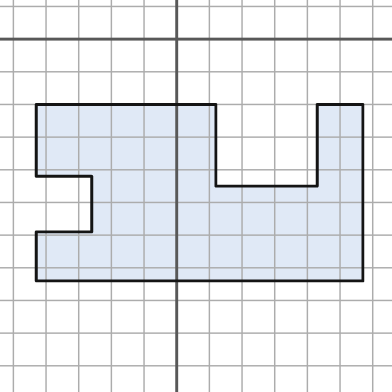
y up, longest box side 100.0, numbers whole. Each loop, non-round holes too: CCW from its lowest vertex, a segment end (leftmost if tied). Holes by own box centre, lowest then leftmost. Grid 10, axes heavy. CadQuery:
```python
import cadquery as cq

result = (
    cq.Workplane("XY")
    .moveTo(-43.0, -74.0)
    .lineTo(57.0, -74.0)
    .lineTo(57.0, -20.0)
    .lineTo(43.0, -20.0)
    .lineTo(43.0, -45.0)
    .lineTo(12.0, -45.0)
    .lineTo(12.0, -20.0)
    .lineTo(-43.0, -20.0)
    .lineTo(-43.0, -42.0)
    .lineTo(-26.0, -42.0)
    .lineTo(-26.0, -59.0)
    .lineTo(-43.0, -59.0)
    .close()
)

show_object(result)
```